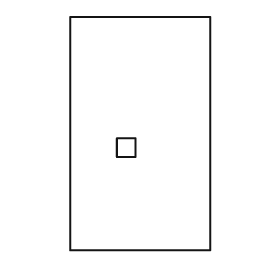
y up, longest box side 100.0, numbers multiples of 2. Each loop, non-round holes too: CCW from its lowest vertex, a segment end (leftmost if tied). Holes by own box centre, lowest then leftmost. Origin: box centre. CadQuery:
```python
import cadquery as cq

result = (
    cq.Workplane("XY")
    .moveTo(-30.0, -50.0)
    .lineTo(30.0, -50.0)
    .lineTo(30.0, 50.0)
    .lineTo(-30.0, 50.0)
    .close()
    .moveTo(-10.0, -10.0)
    .lineTo(-2.0, -10.0)
    .lineTo(-2.0, -2.0)
    .lineTo(-10.0, -2.0)
    .close()
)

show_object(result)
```